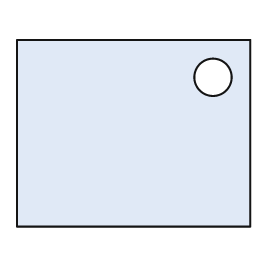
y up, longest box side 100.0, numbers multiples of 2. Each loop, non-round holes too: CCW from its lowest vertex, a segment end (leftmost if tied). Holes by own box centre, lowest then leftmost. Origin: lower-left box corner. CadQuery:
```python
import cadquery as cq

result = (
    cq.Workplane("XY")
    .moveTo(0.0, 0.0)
    .lineTo(100.0, 0.0)
    .lineTo(100.0, 80.0)
    .lineTo(0.0, 80.0)
    .close()
    .moveTo(84.0, 64.0)
    .circle(8.0)
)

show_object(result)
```